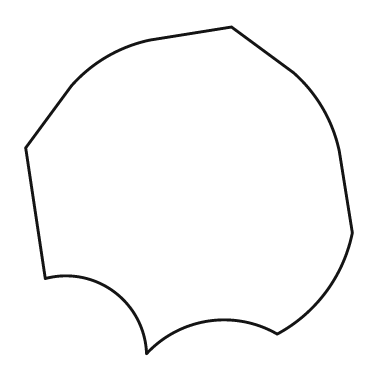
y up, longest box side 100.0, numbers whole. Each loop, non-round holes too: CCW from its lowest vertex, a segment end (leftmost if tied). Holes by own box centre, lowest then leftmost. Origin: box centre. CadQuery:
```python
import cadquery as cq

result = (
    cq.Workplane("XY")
    .moveTo(-13.0, -50.0)
    .threePointArc((6.0, -40.0), (27.0, -44.0))
    .threePointArc((42.0, -31.0), (50.0, -13.0))
    .lineTo(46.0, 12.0)
    .threePointArc((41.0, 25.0), (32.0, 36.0))
    .lineTo(13.0, 50.0)
    .lineTo(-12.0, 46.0)
    .threePointArc((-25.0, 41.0), (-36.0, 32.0))
    .lineTo(-50.0, 13.0)
    .lineTo(-44.0, -27.0)
    .threePointArc((-23.0, -31.0), (-13.0, -50.0))
    .close()
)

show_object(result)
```